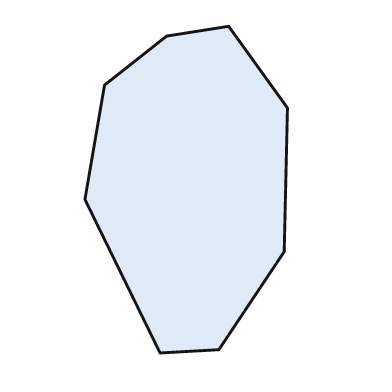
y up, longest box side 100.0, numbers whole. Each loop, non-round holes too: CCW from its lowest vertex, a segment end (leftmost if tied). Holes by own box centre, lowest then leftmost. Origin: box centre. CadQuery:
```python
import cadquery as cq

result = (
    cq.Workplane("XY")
    .moveTo(-8.0, -50.0)
    .lineTo(10.0, -49.0)
    .lineTo(30.0, -19.0)
    .lineTo(31.0, 25.0)
    .lineTo(13.0, 50.0)
    .lineTo(-6.0, 47.0)
    .lineTo(-25.0, 32.0)
    .lineTo(-31.0, -3.0)
    .close()
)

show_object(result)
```